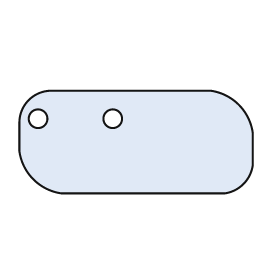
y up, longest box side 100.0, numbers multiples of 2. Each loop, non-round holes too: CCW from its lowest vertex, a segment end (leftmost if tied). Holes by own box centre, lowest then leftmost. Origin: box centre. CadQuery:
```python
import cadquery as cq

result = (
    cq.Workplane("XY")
    .moveTo(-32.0, -22.0)
    .lineTo(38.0, -22.0)
    .threePointArc((46.0, -18.0), (50.0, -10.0))
    .lineTo(50.0, 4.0)
    .threePointArc((44.0, 16.0), (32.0, 22.0))
    .lineTo(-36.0, 22.0)
    .threePointArc((-46.0, 18.0), (-50.0, 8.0))
    .lineTo(-50.0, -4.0)
    .threePointArc((-44.0, -16.0), (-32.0, -22.0))
    .close()
    .moveTo(-42.0, 10.0)
    .circle(4.0)
    .moveTo(-10.0, 10.0)
    .circle(4.0)
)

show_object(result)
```